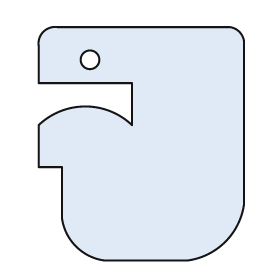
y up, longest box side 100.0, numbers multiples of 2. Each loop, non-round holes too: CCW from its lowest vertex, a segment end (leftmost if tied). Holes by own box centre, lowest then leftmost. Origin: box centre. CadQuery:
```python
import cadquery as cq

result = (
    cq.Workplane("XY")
    .moveTo(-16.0, -50.0)
    .lineTo(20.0, -50.0)
    .threePointArc((36.0, -42.0), (44.0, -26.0))
    .lineTo(44.0, 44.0)
    .threePointArc((42.0, 48.0), (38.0, 50.0))
    .lineTo(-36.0, 50.0)
    .threePointArc((-42.0, 48.0), (-44.0, 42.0))
    .lineTo(-44.0, 26.0)
    .lineTo(-4.0, 26.0)
    .lineTo(-4.0, 8.0)
    .threePointArc((-24.0, 16.0), (-44.0, 8.0))
    .lineTo(-44.0, -10.0)
    .lineTo(-34.0, -10.0)
    .lineTo(-34.0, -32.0)
    .threePointArc((-28.0, -44.0), (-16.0, -50.0))
    .close()
    .moveTo(-22.0, 36.0)
    .circle(4.0)
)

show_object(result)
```